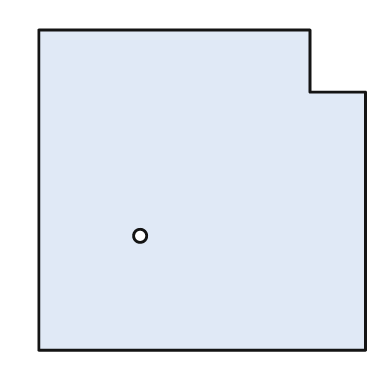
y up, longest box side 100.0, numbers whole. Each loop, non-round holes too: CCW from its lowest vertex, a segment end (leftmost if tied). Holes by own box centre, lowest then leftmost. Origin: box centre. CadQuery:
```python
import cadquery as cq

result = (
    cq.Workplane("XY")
    .moveTo(-50.0, -49.0)
    .lineTo(50.0, -49.0)
    .lineTo(50.0, 30.0)
    .lineTo(33.0, 30.0)
    .lineTo(33.0, 49.0)
    .lineTo(-50.0, 49.0)
    .close()
    .moveTo(-19.0, -14.0)
    .circle(2.0)
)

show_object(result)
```